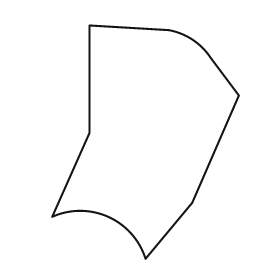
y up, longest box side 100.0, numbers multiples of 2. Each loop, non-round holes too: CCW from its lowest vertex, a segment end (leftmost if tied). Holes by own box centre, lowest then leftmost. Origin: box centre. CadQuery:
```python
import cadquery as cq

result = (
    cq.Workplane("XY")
    .moveTo(0.0, -50.0)
    .lineTo(20.0, -26.0)
    .lineTo(40.0, 20.0)
    .lineTo(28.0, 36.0)
    .threePointArc((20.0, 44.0), (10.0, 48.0))
    .lineTo(-24.0, 50.0)
    .lineTo(-24.0, 4.0)
    .lineTo(-40.0, -32.0)
    .threePointArc((-16.0, -32.0), (0.0, -50.0))
    .close()
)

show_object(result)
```